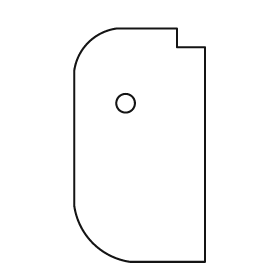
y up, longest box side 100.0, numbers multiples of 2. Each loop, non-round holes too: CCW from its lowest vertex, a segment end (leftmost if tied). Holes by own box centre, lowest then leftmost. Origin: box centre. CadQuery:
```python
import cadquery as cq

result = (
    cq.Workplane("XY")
    .moveTo(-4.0, -50.0)
    .lineTo(28.0, -50.0)
    .lineTo(28.0, 42.0)
    .lineTo(16.0, 42.0)
    .lineTo(16.0, 50.0)
    .lineTo(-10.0, 50.0)
    .threePointArc((-22.0, 44.0), (-28.0, 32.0))
    .lineTo(-28.0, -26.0)
    .threePointArc((-20.0, -42.0), (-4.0, -50.0))
    .close()
    .moveTo(-6.0, 18.0)
    .circle(4.0)
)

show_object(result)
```